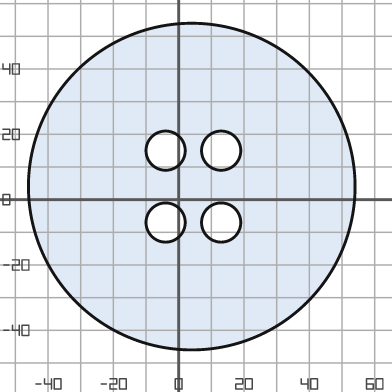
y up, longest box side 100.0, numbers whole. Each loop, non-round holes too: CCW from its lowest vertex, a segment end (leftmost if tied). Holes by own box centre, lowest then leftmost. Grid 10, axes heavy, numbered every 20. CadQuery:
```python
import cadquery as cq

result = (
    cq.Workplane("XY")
    .moveTo(4.0, 4.0)
    .circle(50.0)
    .moveTo(-4.0, -7.0)
    .circle(6.0)
    .moveTo(13.0, -7.0)
    .circle(6.0)
    .moveTo(-4.0, 15.0)
    .circle(6.0)
    .moveTo(13.0, 15.0)
    .circle(6.0)
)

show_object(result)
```